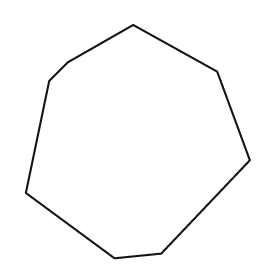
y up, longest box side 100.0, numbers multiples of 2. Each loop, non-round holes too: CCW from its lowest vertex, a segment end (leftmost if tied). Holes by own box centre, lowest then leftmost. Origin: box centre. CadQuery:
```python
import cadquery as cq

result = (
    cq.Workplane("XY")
    .moveTo(-10.0, -50.0)
    .lineTo(10.0, -48.0)
    .lineTo(48.0, -8.0)
    .lineTo(34.0, 30.0)
    .lineTo(-2.0, 50.0)
    .lineTo(-30.0, 34.0)
    .lineTo(-38.0, 26.0)
    .lineTo(-48.0, -22.0)
    .close()
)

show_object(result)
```